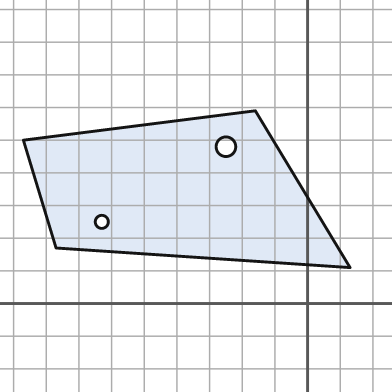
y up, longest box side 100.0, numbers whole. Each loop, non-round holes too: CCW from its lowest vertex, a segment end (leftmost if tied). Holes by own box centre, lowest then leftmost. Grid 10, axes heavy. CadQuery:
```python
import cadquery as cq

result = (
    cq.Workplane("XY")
    .moveTo(13.0, 11.0)
    .lineTo(-16.0, 59.0)
    .lineTo(-87.0, 50.0)
    .lineTo(-77.0, 17.0)
    .close()
    .moveTo(-63.0, 25.0)
    .circle(2.0)
    .moveTo(-25.0, 48.0)
    .circle(3.0)
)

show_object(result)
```